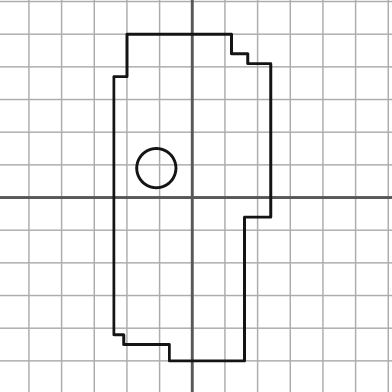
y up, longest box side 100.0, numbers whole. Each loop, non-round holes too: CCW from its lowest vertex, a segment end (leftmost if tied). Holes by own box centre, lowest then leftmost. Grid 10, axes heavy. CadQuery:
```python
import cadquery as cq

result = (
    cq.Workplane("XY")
    .moveTo(-7.0, -50.0)
    .lineTo(16.0, -50.0)
    .lineTo(16.0, -6.0)
    .lineTo(24.0, -6.0)
    .lineTo(24.0, 41.0)
    .lineTo(17.0, 41.0)
    .lineTo(17.0, 44.0)
    .lineTo(12.0, 44.0)
    .lineTo(12.0, 50.0)
    .lineTo(-20.0, 50.0)
    .lineTo(-20.0, 37.0)
    .lineTo(-24.0, 37.0)
    .lineTo(-24.0, -42.0)
    .lineTo(-21.0, -42.0)
    .lineTo(-21.0, -45.0)
    .lineTo(-7.0, -45.0)
    .close()
    .moveTo(-11.0, 9.0)
    .circle(6.0)
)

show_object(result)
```